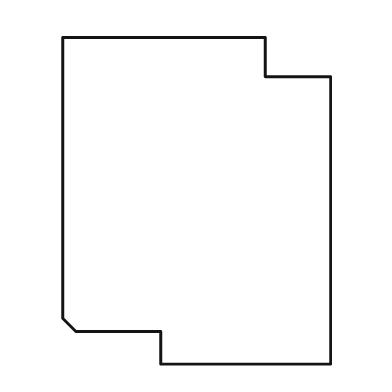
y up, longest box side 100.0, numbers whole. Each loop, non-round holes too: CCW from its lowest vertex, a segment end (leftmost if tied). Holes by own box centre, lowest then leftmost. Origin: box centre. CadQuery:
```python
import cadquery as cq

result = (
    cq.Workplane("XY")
    .moveTo(-11.0, -50.0)
    .lineTo(41.0, -50.0)
    .lineTo(41.0, 38.0)
    .lineTo(21.0, 38.0)
    .lineTo(21.0, 50.0)
    .lineTo(-41.0, 50.0)
    .lineTo(-41.0, -36.0)
    .lineTo(-37.0, -40.0)
    .lineTo(-11.0, -40.0)
    .close()
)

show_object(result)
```